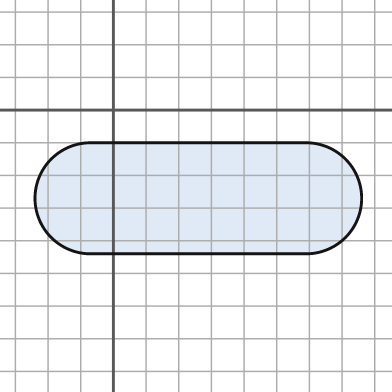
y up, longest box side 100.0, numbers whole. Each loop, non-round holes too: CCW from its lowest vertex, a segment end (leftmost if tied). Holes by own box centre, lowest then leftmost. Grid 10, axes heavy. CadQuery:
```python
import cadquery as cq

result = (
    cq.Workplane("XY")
    .moveTo(-7.0, -44.0)
    .lineTo(59.0, -44.0)
    .threePointArc((76.0, -27.0), (59.0, -10.0))
    .lineTo(-7.0, -10.0)
    .threePointArc((-24.0, -27.0), (-7.0, -44.0))
    .close()
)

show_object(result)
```